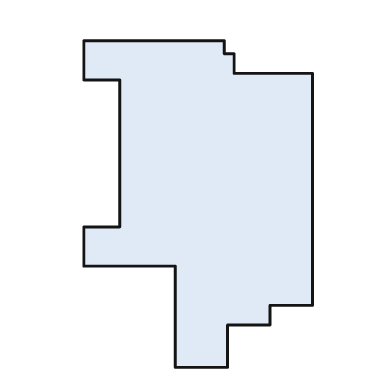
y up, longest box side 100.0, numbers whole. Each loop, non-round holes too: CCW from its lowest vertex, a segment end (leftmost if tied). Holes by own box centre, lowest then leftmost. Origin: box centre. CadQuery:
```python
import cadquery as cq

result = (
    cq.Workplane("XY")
    .moveTo(-7.0, -50.0)
    .lineTo(9.0, -50.0)
    .lineTo(9.0, -37.0)
    .lineTo(22.0, -37.0)
    .lineTo(22.0, -31.0)
    .lineTo(35.0, -31.0)
    .lineTo(35.0, 40.0)
    .lineTo(11.0, 40.0)
    .lineTo(11.0, 46.0)
    .lineTo(8.0, 46.0)
    .lineTo(8.0, 50.0)
    .lineTo(-35.0, 50.0)
    .lineTo(-35.0, 38.0)
    .lineTo(-24.0, 38.0)
    .lineTo(-24.0, -7.0)
    .lineTo(-35.0, -7.0)
    .lineTo(-35.0, -19.0)
    .lineTo(-7.0, -19.0)
    .close()
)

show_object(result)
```